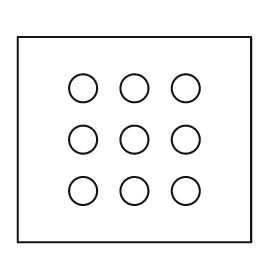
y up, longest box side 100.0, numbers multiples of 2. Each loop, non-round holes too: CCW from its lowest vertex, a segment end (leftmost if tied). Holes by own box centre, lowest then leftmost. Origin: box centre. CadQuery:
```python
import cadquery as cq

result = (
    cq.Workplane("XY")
    .moveTo(-50.0, -44.0)
    .lineTo(50.0, -44.0)
    .lineTo(50.0, 44.0)
    .lineTo(-50.0, 44.0)
    .close()
    .moveTo(-22.0, -22.0)
    .circle(6.0)
    .moveTo(0.0, -22.0)
    .circle(6.0)
    .moveTo(22.0, -22.0)
    .circle(6.0)
    .moveTo(-22.0, 0.0)
    .circle(6.0)
    .moveTo(0.0, 0.0)
    .circle(6.0)
    .moveTo(22.0, 0.0)
    .circle(6.0)
    .moveTo(-22.0, 22.0)
    .circle(6.0)
    .moveTo(0.0, 22.0)
    .circle(6.0)
    .moveTo(22.0, 22.0)
    .circle(6.0)
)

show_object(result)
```